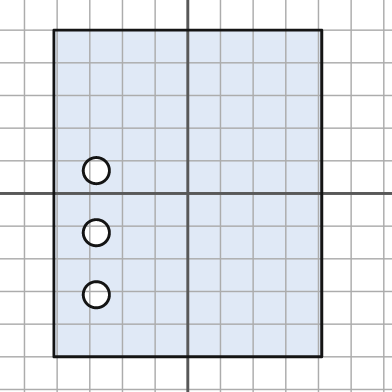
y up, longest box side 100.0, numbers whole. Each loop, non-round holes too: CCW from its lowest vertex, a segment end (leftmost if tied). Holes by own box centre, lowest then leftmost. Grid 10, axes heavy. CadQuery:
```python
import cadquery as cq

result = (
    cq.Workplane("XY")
    .moveTo(-41.0, -50.0)
    .lineTo(41.0, -50.0)
    .lineTo(41.0, 50.0)
    .lineTo(-41.0, 50.0)
    .close()
    .moveTo(-28.0, -31.0)
    .circle(4.0)
    .moveTo(-28.0, -12.0)
    .circle(4.0)
    .moveTo(-28.0, 7.0)
    .circle(4.0)
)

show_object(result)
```